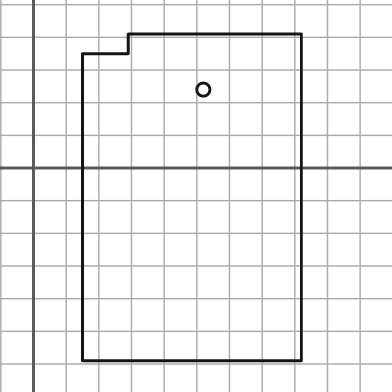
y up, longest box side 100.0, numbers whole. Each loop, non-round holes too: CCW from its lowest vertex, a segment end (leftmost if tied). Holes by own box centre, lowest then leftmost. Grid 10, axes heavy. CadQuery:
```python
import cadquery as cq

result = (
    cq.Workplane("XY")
    .moveTo(15.0, -59.0)
    .lineTo(82.0, -59.0)
    .lineTo(82.0, 41.0)
    .lineTo(29.0, 41.0)
    .lineTo(29.0, 35.0)
    .lineTo(15.0, 35.0)
    .close()
    .moveTo(52.0, 24.0)
    .circle(2.0)
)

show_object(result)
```